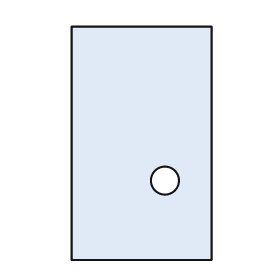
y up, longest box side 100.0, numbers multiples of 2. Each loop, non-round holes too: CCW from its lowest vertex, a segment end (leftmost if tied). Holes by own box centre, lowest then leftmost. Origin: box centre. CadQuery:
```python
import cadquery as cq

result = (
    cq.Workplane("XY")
    .moveTo(-30.0, -50.0)
    .lineTo(30.0, -50.0)
    .lineTo(30.0, 50.0)
    .lineTo(-30.0, 50.0)
    .close()
    .moveTo(10.0, -16.0)
    .circle(6.0)
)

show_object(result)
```